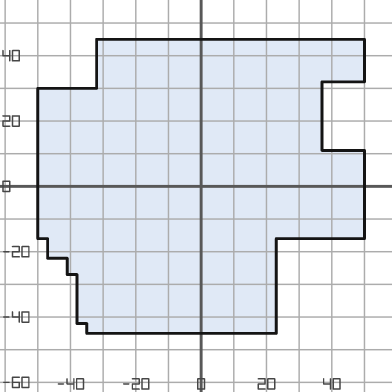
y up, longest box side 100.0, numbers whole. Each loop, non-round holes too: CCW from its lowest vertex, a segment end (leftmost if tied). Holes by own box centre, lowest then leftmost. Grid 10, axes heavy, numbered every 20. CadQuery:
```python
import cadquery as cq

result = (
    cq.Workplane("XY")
    .moveTo(-35.0, -45.0)
    .lineTo(23.0, -45.0)
    .lineTo(23.0, -16.0)
    .lineTo(50.0, -16.0)
    .lineTo(50.0, 11.0)
    .lineTo(37.0, 11.0)
    .lineTo(37.0, 32.0)
    .lineTo(50.0, 32.0)
    .lineTo(50.0, 45.0)
    .lineTo(-32.0, 45.0)
    .lineTo(-32.0, 30.0)
    .lineTo(-50.0, 30.0)
    .lineTo(-50.0, -16.0)
    .lineTo(-47.0, -16.0)
    .lineTo(-47.0, -22.0)
    .lineTo(-41.0, -22.0)
    .lineTo(-41.0, -27.0)
    .lineTo(-38.0, -27.0)
    .lineTo(-38.0, -42.0)
    .lineTo(-35.0, -42.0)
    .close()
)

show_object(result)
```